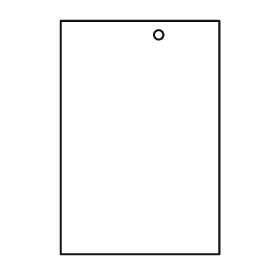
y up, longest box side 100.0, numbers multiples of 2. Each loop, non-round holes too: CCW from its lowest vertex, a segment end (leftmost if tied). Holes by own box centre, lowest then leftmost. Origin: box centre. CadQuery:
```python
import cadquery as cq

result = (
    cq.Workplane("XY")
    .moveTo(-34.0, -50.0)
    .lineTo(34.0, -50.0)
    .lineTo(34.0, 50.0)
    .lineTo(-34.0, 50.0)
    .close()
    .moveTo(8.0, 44.0)
    .circle(2.0)
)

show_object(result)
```